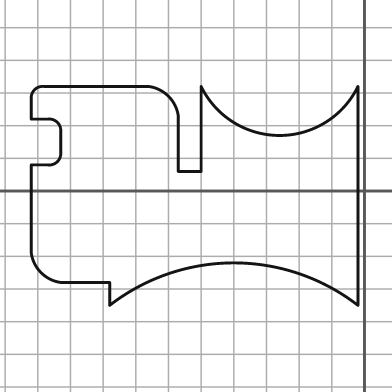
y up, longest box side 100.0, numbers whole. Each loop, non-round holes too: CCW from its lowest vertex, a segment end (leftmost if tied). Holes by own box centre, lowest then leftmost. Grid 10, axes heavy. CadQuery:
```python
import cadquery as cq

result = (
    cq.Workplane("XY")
    .moveTo(-78.0, -35.0)
    .threePointArc((-40.0, -22.0), (-2.0, -35.0))
    .lineTo(-2.0, 32.0)
    .threePointArc((-26.0, 17.0), (-50.0, 32.0))
    .lineTo(-50.0, 6.0)
    .lineTo(-57.0, 6.0)
    .lineTo(-57.0, 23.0)
    .threePointArc((-60.0, 29.0), (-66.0, 32.0))
    .lineTo(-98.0, 32.0)
    .threePointArc((-101.0, 31.0), (-102.0, 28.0))
    .lineTo(-102.0, 22.0)
    .lineTo(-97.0, 22.0)
    .threePointArc((-94.0, 21.0), (-93.0, 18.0))
    .lineTo(-93.0, 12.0)
    .threePointArc((-94.0, 9.0), (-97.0, 8.0))
    .lineTo(-102.0, 8.0)
    .lineTo(-102.0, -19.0)
    .threePointArc((-99.0, -25.0), (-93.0, -28.0))
    .lineTo(-78.0, -28.0)
    .close()
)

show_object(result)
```